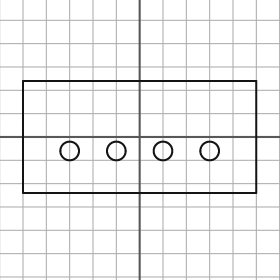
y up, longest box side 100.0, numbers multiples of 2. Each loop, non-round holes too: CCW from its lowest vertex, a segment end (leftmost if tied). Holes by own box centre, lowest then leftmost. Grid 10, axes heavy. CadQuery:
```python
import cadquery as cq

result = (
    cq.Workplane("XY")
    .moveTo(-50.0, -24.0)
    .lineTo(50.0, -24.0)
    .lineTo(50.0, 24.0)
    .lineTo(-50.0, 24.0)
    .close()
    .moveTo(-30.0, -6.0)
    .circle(4.0)
    .moveTo(-10.0, -6.0)
    .circle(4.0)
    .moveTo(10.0, -6.0)
    .circle(4.0)
    .moveTo(30.0, -6.0)
    .circle(4.0)
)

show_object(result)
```